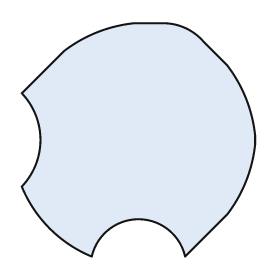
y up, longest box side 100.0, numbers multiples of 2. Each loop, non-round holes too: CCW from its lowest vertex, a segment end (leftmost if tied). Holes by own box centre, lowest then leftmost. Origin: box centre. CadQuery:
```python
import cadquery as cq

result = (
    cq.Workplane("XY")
    .moveTo(-20.0, -50.0)
    .threePointArc((0.0, -34.0), (20.0, -50.0))
    .lineTo(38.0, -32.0)
    .threePointArc((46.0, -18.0), (50.0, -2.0))
    .lineTo(50.0, 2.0)
    .threePointArc((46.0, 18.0), (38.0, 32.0))
    .lineTo(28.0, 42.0)
    .threePointArc((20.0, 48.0), (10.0, 50.0))
    .lineTo(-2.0, 50.0)
    .threePointArc((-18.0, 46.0), (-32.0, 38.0))
    .lineTo(-50.0, 20.0)
    .threePointArc((-42.0, 0.0), (-50.0, -20.0))
    .threePointArc((-38.0, -38.0), (-20.0, -50.0))
    .close()
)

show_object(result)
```